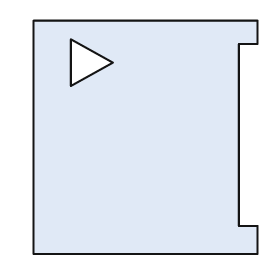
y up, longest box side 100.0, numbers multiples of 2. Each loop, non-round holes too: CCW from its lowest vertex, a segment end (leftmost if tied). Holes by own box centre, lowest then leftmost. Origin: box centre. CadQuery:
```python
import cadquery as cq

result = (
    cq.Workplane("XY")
    .moveTo(-48.0, -50.0)
    .lineTo(48.0, -50.0)
    .lineTo(48.0, -38.0)
    .lineTo(40.0, -38.0)
    .lineTo(40.0, 40.0)
    .lineTo(48.0, 40.0)
    .lineTo(48.0, 50.0)
    .lineTo(-48.0, 50.0)
    .close()
    .moveTo(-32.0, 22.0)
    .lineTo(-14.0, 32.0)
    .lineTo(-32.0, 42.0)
    .close()
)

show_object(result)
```